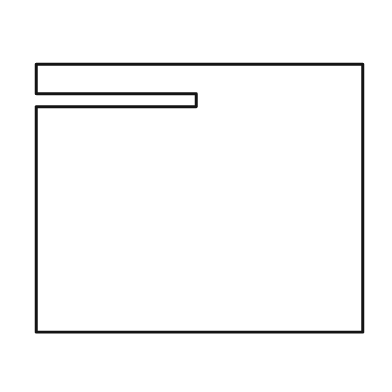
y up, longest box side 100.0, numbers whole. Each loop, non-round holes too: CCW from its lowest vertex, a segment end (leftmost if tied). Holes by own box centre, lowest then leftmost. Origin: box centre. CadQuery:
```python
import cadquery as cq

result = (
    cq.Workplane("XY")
    .moveTo(-50.0, -41.0)
    .lineTo(50.0, -41.0)
    .lineTo(50.0, 41.0)
    .lineTo(-50.0, 41.0)
    .lineTo(-50.0, 32.0)
    .lineTo(-1.0, 32.0)
    .lineTo(-1.0, 28.0)
    .lineTo(-50.0, 28.0)
    .close()
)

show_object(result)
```